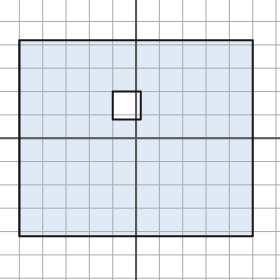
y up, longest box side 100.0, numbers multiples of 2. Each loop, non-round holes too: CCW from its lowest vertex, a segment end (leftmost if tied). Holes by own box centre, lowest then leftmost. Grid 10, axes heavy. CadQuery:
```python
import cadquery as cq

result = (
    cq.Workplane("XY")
    .moveTo(-50.0, -42.0)
    .lineTo(50.0, -42.0)
    .lineTo(50.0, 42.0)
    .lineTo(-50.0, 42.0)
    .close()
    .moveTo(-10.0, 8.0)
    .lineTo(2.0, 8.0)
    .lineTo(2.0, 20.0)
    .lineTo(-10.0, 20.0)
    .close()
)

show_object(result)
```